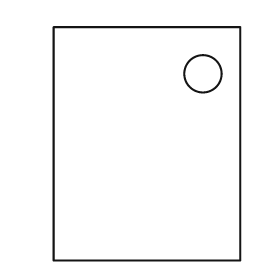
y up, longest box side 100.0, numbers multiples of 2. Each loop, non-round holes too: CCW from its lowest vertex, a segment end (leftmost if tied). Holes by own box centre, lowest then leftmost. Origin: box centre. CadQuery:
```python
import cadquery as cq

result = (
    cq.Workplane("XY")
    .moveTo(-40.0, -50.0)
    .lineTo(40.0, -50.0)
    .lineTo(40.0, 50.0)
    .lineTo(-40.0, 50.0)
    .close()
    .moveTo(24.0, 30.0)
    .circle(8.0)
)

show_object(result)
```